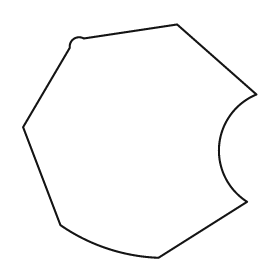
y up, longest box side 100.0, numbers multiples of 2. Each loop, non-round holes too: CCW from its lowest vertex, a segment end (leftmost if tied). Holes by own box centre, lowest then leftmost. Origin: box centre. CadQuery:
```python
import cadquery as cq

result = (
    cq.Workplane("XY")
    .moveTo(8.0, -50.0)
    .lineTo(46.0, -26.0)
    .threePointArc((34.0, -2.0), (50.0, 20.0))
    .lineTo(16.0, 50.0)
    .lineTo(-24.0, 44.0)
    .threePointArc((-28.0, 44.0), (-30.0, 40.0))
    .lineTo(-50.0, 6.0)
    .lineTo(-34.0, -36.0)
    .threePointArc((-14.0, -46.0), (8.0, -50.0))
    .close()
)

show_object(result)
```